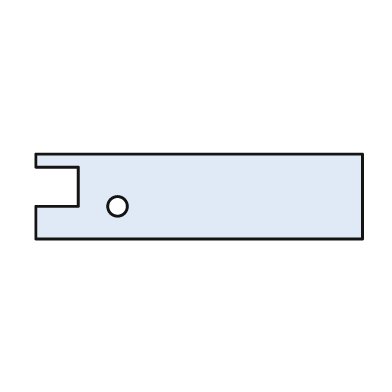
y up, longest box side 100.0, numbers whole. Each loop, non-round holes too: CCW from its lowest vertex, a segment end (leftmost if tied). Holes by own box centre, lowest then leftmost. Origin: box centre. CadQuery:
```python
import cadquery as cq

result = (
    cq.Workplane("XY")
    .moveTo(-50.0, -13.0)
    .lineTo(50.0, -13.0)
    .lineTo(50.0, 13.0)
    .lineTo(-50.0, 13.0)
    .lineTo(-50.0, 9.0)
    .lineTo(-37.0, 9.0)
    .lineTo(-37.0, -3.0)
    .lineTo(-50.0, -3.0)
    .close()
    .moveTo(-25.0, -3.0)
    .circle(3.0)
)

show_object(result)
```